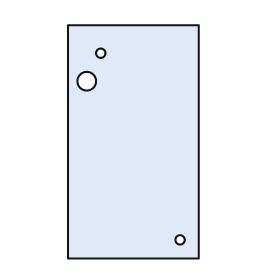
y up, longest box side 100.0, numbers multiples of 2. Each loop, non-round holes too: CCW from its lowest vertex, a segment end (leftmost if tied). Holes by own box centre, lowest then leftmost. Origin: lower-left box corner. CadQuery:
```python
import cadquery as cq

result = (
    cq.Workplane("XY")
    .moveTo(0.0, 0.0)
    .lineTo(56.0, 0.0)
    .lineTo(56.0, 100.0)
    .lineTo(0.0, 100.0)
    .close()
    .moveTo(48.0, 8.0)
    .circle(2.0)
    .moveTo(8.0, 76.0)
    .circle(4.0)
    .moveTo(14.0, 88.0)
    .circle(2.0)
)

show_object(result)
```